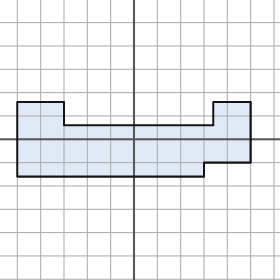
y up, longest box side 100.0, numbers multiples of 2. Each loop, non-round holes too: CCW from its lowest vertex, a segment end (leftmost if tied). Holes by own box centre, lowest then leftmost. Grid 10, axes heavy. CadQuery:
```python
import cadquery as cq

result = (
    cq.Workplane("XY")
    .moveTo(-50.0, -16.0)
    .lineTo(30.0, -16.0)
    .lineTo(30.0, -10.0)
    .lineTo(50.0, -10.0)
    .lineTo(50.0, 16.0)
    .lineTo(34.0, 16.0)
    .lineTo(34.0, 6.0)
    .lineTo(-30.0, 6.0)
    .lineTo(-30.0, 16.0)
    .lineTo(-50.0, 16.0)
    .close()
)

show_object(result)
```